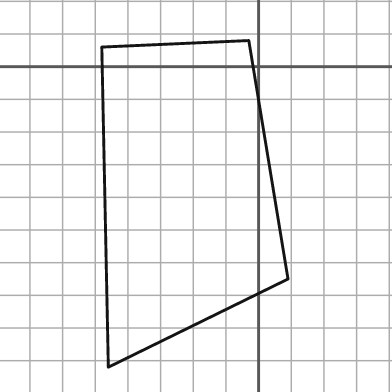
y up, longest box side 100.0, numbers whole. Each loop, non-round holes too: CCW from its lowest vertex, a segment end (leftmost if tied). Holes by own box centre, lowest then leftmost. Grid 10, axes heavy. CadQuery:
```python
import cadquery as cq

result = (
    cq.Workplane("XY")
    .moveTo(-46.0, -92.0)
    .lineTo(9.0, -65.0)
    .lineTo(-3.0, 8.0)
    .lineTo(-48.0, 6.0)
    .close()
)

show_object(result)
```